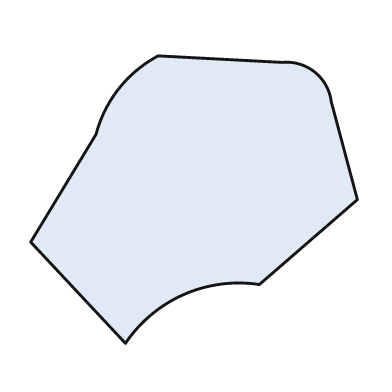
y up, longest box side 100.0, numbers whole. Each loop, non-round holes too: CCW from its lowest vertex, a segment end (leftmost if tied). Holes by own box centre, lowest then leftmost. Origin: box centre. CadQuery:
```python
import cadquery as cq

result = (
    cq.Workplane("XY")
    .moveTo(-21.0, -44.0)
    .threePointArc((-3.0, -29.0), (20.0, -26.0))
    .lineTo(50.0, 0.0)
    .lineTo(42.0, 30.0)
    .threePointArc((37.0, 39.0), (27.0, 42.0))
    .lineTo(-11.0, 44.0)
    .threePointArc((-23.0, 34.0), (-30.0, 20.0))
    .lineTo(-50.0, -13.0)
    .close()
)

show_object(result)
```